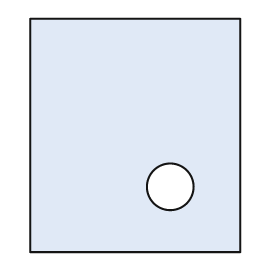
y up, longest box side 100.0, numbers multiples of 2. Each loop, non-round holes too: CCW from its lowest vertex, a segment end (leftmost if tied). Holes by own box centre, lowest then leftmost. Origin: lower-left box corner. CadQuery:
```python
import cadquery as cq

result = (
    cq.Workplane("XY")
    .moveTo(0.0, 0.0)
    .lineTo(90.0, 0.0)
    .lineTo(90.0, 100.0)
    .lineTo(0.0, 100.0)
    .close()
    .moveTo(60.0, 28.0)
    .circle(10.0)
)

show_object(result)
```